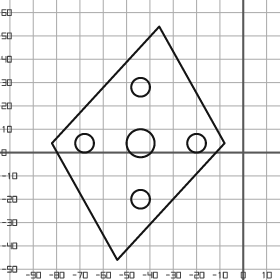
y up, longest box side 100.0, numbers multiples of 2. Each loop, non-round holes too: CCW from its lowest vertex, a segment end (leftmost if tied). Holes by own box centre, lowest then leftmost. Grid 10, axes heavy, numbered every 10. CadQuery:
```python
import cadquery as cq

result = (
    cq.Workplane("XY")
    .moveTo(-54.0, -46.0)
    .lineTo(-8.0, 4.0)
    .lineTo(-36.0, 54.0)
    .lineTo(-82.0, 4.0)
    .close()
    .moveTo(-44.0, -20.0)
    .circle(4.0)
    .moveTo(-68.0, 4.0)
    .circle(4.0)
    .moveTo(-44.0, 4.0)
    .circle(6.0)
    .moveTo(-20.0, 4.0)
    .circle(4.0)
    .moveTo(-44.0, 28.0)
    .circle(4.0)
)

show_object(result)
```